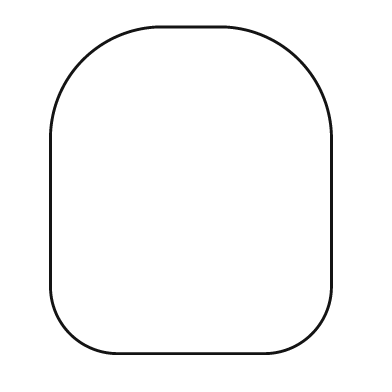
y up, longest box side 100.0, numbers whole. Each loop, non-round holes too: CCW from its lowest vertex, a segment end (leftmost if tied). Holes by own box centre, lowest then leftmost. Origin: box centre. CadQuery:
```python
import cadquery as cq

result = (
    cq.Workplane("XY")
    .moveTo(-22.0, -50.0)
    .lineTo(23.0, -50.0)
    .threePointArc((37.0, -44.0), (43.0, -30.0))
    .lineTo(43.0, 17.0)
    .threePointArc((33.0, 40.0), (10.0, 50.0))
    .lineTo(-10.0, 50.0)
    .threePointArc((-33.0, 40.0), (-43.0, 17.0))
    .lineTo(-43.0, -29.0)
    .threePointArc((-37.0, -44.0), (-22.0, -50.0))
    .close()
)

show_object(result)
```